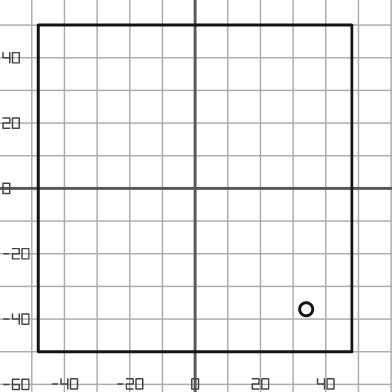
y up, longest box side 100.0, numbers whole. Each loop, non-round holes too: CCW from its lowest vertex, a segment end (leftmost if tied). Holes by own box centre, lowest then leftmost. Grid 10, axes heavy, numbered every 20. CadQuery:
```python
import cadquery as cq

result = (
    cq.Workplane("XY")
    .moveTo(-48.0, -50.0)
    .lineTo(48.0, -50.0)
    .lineTo(48.0, 50.0)
    .lineTo(-48.0, 50.0)
    .close()
    .moveTo(34.0, -37.0)
    .circle(2.0)
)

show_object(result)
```